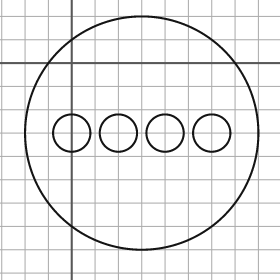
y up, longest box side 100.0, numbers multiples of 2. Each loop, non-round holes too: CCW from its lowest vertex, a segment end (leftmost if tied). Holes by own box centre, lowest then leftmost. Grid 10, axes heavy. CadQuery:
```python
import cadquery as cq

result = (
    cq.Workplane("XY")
    .moveTo(30.0, -30.0)
    .circle(50.0)
    .moveTo(0.0, -30.0)
    .circle(8.0)
    .moveTo(20.0, -30.0)
    .circle(8.0)
    .moveTo(40.0, -30.0)
    .circle(8.0)
    .moveTo(60.0, -30.0)
    .circle(8.0)
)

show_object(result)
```